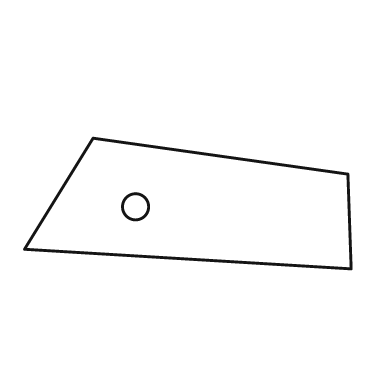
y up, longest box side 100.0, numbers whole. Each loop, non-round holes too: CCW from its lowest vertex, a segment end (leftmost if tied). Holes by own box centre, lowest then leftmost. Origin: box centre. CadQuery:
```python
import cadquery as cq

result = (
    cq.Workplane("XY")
    .moveTo(50.0, -20.0)
    .lineTo(49.0, 9.0)
    .lineTo(-29.0, 20.0)
    .lineTo(-50.0, -14.0)
    .close()
    .moveTo(-16.0, -1.0)
    .circle(4.0)
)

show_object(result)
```